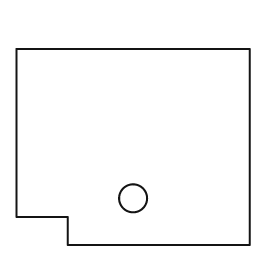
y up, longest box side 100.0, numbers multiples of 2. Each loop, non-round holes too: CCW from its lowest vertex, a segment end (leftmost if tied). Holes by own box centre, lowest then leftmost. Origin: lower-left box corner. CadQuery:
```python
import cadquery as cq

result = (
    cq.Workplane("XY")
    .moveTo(22.0, 0.0)
    .lineTo(100.0, 0.0)
    .lineTo(100.0, 84.0)
    .lineTo(0.0, 84.0)
    .lineTo(0.0, 12.0)
    .lineTo(22.0, 12.0)
    .close()
    .moveTo(50.0, 20.0)
    .circle(6.0)
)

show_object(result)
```